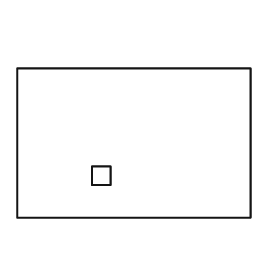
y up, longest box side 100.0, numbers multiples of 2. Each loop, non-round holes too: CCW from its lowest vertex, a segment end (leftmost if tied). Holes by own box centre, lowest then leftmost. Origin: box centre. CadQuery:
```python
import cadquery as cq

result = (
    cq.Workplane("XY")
    .moveTo(-50.0, -32.0)
    .lineTo(50.0, -32.0)
    .lineTo(50.0, 32.0)
    .lineTo(-50.0, 32.0)
    .close()
    .moveTo(-18.0, -18.0)
    .lineTo(-10.0, -18.0)
    .lineTo(-10.0, -10.0)
    .lineTo(-18.0, -10.0)
    .close()
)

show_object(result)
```